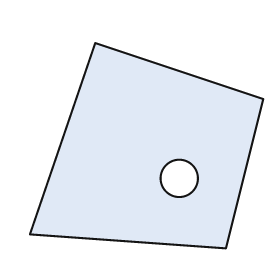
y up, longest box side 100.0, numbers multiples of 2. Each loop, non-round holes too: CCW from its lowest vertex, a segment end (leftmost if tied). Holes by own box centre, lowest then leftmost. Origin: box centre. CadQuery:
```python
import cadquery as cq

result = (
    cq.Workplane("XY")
    .moveTo(34.0, -44.0)
    .lineTo(50.0, 20.0)
    .lineTo(-22.0, 44.0)
    .lineTo(-50.0, -38.0)
    .close()
    .moveTo(14.0, -14.0)
    .circle(8.0)
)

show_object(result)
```